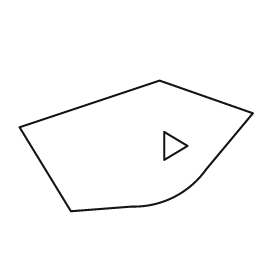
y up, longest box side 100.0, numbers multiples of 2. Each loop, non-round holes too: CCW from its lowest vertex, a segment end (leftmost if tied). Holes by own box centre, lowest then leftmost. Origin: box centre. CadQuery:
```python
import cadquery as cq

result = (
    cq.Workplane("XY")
    .moveTo(-28.0, -28.0)
    .lineTo(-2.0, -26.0)
    .threePointArc((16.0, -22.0), (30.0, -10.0))
    .lineTo(50.0, 14.0)
    .lineTo(10.0, 28.0)
    .lineTo(-50.0, 8.0)
    .close()
    .moveTo(12.0, -6.0)
    .lineTo(22.0, 0.0)
    .lineTo(12.0, 6.0)
    .close()
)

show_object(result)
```